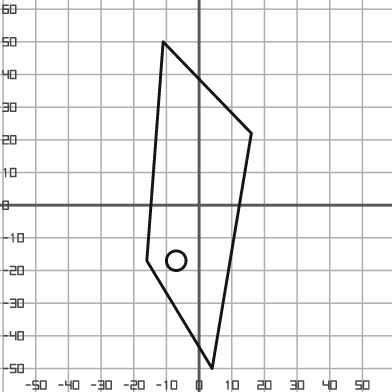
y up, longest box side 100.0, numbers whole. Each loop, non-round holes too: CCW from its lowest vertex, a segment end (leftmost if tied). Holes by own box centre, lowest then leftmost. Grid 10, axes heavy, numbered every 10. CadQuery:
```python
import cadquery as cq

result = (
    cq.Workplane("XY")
    .moveTo(4.0, -50.0)
    .lineTo(16.0, 22.0)
    .lineTo(-11.0, 50.0)
    .lineTo(-16.0, -17.0)
    .close()
    .moveTo(-7.0, -17.0)
    .circle(3.0)
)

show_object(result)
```